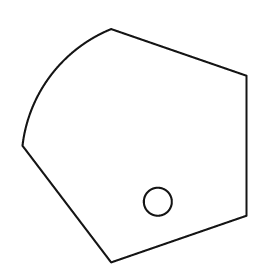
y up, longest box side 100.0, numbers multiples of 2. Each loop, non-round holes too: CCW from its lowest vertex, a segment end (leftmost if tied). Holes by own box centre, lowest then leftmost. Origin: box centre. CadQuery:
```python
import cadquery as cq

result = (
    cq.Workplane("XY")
    .moveTo(-10.0, -50.0)
    .lineTo(48.0, -30.0)
    .lineTo(48.0, 30.0)
    .lineTo(-10.0, 50.0)
    .threePointArc((-36.0, 30.0), (-48.0, 0.0))
    .close()
    .moveTo(10.0, -24.0)
    .circle(6.0)
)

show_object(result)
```